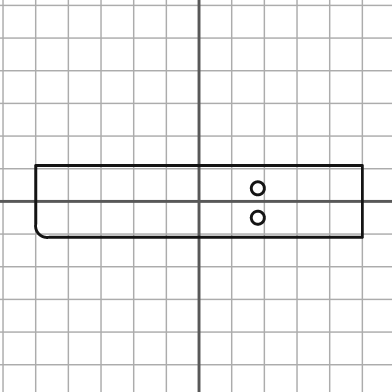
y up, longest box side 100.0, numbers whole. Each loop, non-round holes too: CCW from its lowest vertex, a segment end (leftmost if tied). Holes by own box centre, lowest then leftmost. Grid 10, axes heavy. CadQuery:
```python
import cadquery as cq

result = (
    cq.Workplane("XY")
    .moveTo(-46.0, -11.0)
    .lineTo(50.0, -11.0)
    .lineTo(50.0, 11.0)
    .lineTo(-50.0, 11.0)
    .lineTo(-50.0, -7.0)
    .threePointArc((-49.0, -10.0), (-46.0, -11.0))
    .close()
    .moveTo(18.0, -5.0)
    .circle(2.0)
    .moveTo(18.0, 4.0)
    .circle(2.0)
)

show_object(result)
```